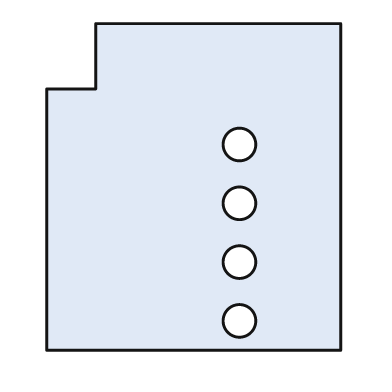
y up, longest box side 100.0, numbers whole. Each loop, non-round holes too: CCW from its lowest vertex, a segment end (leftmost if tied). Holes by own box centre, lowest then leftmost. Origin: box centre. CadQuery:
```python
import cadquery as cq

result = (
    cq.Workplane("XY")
    .moveTo(-45.0, -50.0)
    .lineTo(45.0, -50.0)
    .lineTo(45.0, 50.0)
    .lineTo(-30.0, 50.0)
    .lineTo(-30.0, 30.0)
    .lineTo(-45.0, 30.0)
    .close()
    .moveTo(14.0, -41.0)
    .circle(5.0)
    .moveTo(14.0, -23.0)
    .circle(5.0)
    .moveTo(14.0, -5.0)
    .circle(5.0)
    .moveTo(14.0, 13.0)
    .circle(5.0)
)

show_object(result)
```